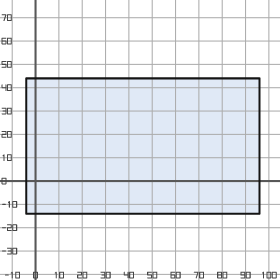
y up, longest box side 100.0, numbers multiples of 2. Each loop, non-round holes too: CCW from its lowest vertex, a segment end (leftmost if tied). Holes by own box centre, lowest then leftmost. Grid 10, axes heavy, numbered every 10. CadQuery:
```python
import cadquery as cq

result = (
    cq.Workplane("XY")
    .moveTo(-4.0, -14.0)
    .lineTo(96.0, -14.0)
    .lineTo(96.0, 44.0)
    .lineTo(-4.0, 44.0)
    .close()
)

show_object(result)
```